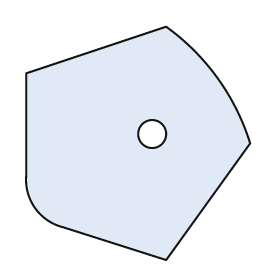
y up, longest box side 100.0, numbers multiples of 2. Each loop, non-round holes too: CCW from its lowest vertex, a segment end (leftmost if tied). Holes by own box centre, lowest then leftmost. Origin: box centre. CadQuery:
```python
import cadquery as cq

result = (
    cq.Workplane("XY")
    .moveTo(12.0, -50.0)
    .lineTo(48.0, 0.0)
    .threePointArc((34.0, 28.0), (12.0, 50.0))
    .lineTo(-48.0, 30.0)
    .lineTo(-48.0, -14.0)
    .threePointArc((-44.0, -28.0), (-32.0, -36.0))
    .close()
    .moveTo(6.0, 4.0)
    .circle(6.0)
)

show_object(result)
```